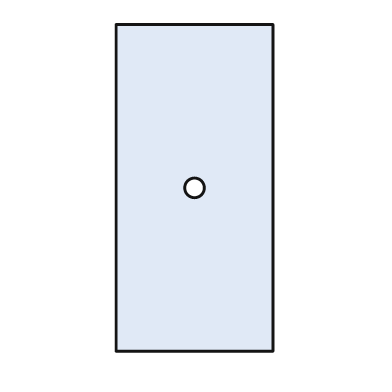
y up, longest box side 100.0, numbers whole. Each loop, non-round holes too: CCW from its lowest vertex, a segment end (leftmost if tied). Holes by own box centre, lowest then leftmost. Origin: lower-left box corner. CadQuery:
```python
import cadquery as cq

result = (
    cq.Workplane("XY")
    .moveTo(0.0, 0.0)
    .lineTo(48.0, 0.0)
    .lineTo(48.0, 100.0)
    .lineTo(0.0, 100.0)
    .close()
    .moveTo(24.0, 50.0)
    .circle(3.0)
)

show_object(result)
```